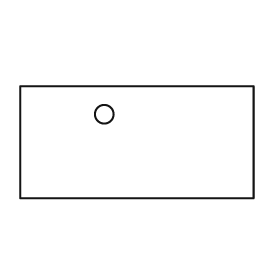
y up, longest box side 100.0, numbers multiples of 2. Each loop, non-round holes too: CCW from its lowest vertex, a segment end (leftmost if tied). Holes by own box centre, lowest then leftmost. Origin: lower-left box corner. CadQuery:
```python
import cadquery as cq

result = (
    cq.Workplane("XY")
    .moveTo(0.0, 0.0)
    .lineTo(100.0, 0.0)
    .lineTo(100.0, 48.0)
    .lineTo(0.0, 48.0)
    .close()
    .moveTo(36.0, 36.0)
    .circle(4.0)
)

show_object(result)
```